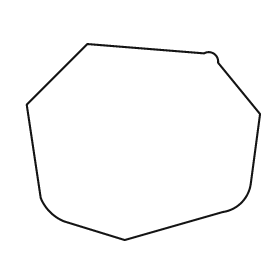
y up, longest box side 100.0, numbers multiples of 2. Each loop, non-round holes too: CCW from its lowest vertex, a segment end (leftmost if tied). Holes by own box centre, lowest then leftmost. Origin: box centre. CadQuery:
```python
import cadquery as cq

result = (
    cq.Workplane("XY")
    .moveTo(-8.0, -42.0)
    .lineTo(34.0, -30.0)
    .threePointArc((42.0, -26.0), (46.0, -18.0))
    .lineTo(50.0, 12.0)
    .lineTo(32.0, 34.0)
    .threePointArc((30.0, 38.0), (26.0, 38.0))
    .lineTo(-24.0, 42.0)
    .lineTo(-50.0, 16.0)
    .lineTo(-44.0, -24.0)
    .threePointArc((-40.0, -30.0), (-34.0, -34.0))
    .close()
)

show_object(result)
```